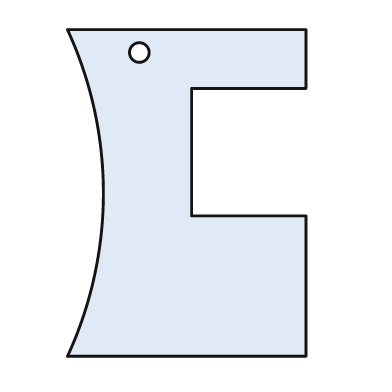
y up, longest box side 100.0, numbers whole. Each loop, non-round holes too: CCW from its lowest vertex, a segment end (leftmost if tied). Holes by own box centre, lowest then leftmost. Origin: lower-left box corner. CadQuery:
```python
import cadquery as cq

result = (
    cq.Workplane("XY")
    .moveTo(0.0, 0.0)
    .lineTo(73.0, 0.0)
    .lineTo(73.0, 43.0)
    .lineTo(38.0, 43.0)
    .lineTo(38.0, 82.0)
    .lineTo(73.0, 82.0)
    .lineTo(73.0, 100.0)
    .lineTo(0.0, 100.0)
    .threePointArc((11.0, 50.0), (0.0, 0.0))
    .close()
    .moveTo(22.0, 93.0)
    .circle(3.0)
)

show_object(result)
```